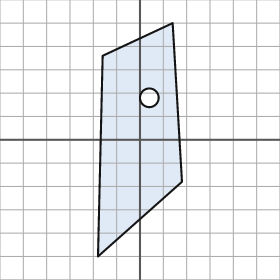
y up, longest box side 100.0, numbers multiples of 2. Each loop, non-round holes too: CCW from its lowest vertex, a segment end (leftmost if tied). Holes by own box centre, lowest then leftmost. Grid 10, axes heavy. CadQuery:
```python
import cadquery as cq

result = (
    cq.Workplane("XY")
    .moveTo(-18.0, -50.0)
    .lineTo(18.0, -18.0)
    .lineTo(14.0, 50.0)
    .lineTo(-16.0, 36.0)
    .close()
    .moveTo(4.0, 18.0)
    .circle(4.0)
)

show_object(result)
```